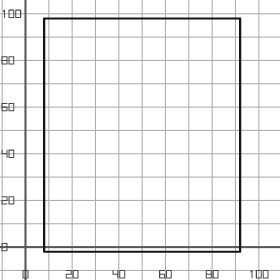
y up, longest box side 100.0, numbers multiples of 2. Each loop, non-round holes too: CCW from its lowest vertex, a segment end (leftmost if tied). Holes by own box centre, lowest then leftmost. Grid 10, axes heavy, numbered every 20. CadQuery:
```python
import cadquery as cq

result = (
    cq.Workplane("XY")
    .moveTo(8.0, -2.0)
    .lineTo(92.0, -2.0)
    .lineTo(92.0, 98.0)
    .lineTo(8.0, 98.0)
    .close()
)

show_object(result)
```